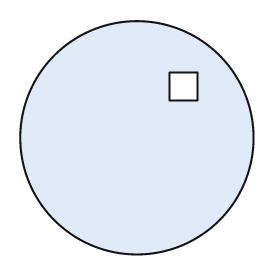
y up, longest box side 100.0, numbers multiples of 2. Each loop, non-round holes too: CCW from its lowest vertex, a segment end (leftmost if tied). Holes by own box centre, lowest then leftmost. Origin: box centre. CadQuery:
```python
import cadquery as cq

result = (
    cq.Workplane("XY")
    .moveTo(0.0, 0.0)
    .circle(50.0)
    .moveTo(14.0, 16.0)
    .lineTo(26.0, 16.0)
    .lineTo(26.0, 28.0)
    .lineTo(14.0, 28.0)
    .close()
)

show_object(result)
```